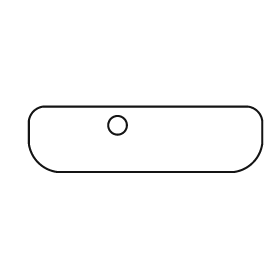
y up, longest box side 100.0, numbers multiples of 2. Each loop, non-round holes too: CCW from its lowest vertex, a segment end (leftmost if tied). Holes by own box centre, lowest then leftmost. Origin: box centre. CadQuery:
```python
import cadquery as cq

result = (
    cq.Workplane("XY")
    .moveTo(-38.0, -14.0)
    .lineTo(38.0, -14.0)
    .threePointArc((46.0, -10.0), (50.0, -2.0))
    .lineTo(50.0, 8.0)
    .threePointArc((48.0, 12.0), (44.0, 14.0))
    .lineTo(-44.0, 14.0)
    .threePointArc((-48.0, 12.0), (-50.0, 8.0))
    .lineTo(-50.0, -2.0)
    .threePointArc((-46.0, -10.0), (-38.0, -14.0))
    .close()
    .moveTo(-12.0, 6.0)
    .circle(4.0)
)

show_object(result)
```